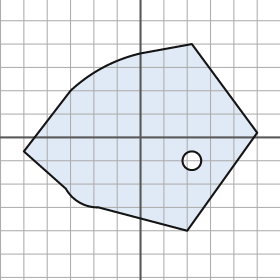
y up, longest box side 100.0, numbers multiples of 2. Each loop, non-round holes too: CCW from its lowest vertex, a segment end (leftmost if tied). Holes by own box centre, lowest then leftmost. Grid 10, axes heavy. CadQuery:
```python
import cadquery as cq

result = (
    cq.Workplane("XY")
    .moveTo(20.0, -40.0)
    .lineTo(50.0, 2.0)
    .lineTo(22.0, 40.0)
    .lineTo(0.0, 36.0)
    .threePointArc((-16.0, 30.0), (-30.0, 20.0))
    .lineTo(-50.0, -6.0)
    .lineTo(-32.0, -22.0)
    .threePointArc((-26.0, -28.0), (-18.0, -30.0))
    .close()
    .moveTo(22.0, -10.0)
    .circle(4.0)
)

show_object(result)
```